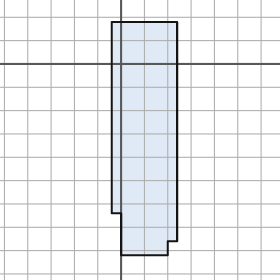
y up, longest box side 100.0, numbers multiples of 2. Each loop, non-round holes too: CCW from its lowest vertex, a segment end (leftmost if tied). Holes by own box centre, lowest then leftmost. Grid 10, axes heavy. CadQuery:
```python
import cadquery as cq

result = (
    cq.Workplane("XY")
    .moveTo(0.0, -82.0)
    .lineTo(20.0, -82.0)
    .lineTo(20.0, -76.0)
    .lineTo(24.0, -76.0)
    .lineTo(24.0, 18.0)
    .lineTo(-4.0, 18.0)
    .lineTo(-4.0, -64.0)
    .lineTo(0.0, -64.0)
    .close()
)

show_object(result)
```